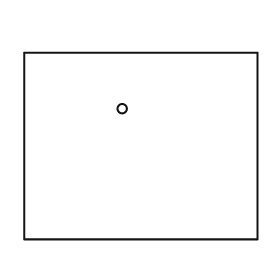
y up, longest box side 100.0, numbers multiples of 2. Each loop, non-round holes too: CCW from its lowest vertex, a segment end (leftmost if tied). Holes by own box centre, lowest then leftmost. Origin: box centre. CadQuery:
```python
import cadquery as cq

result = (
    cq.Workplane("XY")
    .moveTo(-50.0, -40.0)
    .lineTo(50.0, -40.0)
    .lineTo(50.0, 40.0)
    .lineTo(-50.0, 40.0)
    .close()
    .moveTo(-8.0, 16.0)
    .circle(2.0)
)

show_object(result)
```